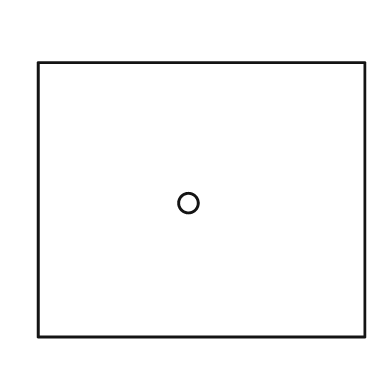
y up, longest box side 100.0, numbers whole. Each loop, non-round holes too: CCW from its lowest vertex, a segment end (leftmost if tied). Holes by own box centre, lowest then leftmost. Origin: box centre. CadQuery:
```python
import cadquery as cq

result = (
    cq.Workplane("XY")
    .moveTo(-50.0, -42.0)
    .lineTo(50.0, -42.0)
    .lineTo(50.0, 42.0)
    .lineTo(-50.0, 42.0)
    .close()
    .moveTo(-4.0, -1.0)
    .circle(3.0)
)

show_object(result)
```